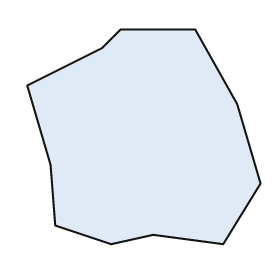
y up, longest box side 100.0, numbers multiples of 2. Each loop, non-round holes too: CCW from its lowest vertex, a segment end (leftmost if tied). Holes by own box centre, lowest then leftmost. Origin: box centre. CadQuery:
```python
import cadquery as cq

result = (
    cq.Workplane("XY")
    .moveTo(-14.0, -46.0)
    .lineTo(4.0, -42.0)
    .lineTo(34.0, -46.0)
    .lineTo(50.0, -20.0)
    .lineTo(40.0, 14.0)
    .lineTo(22.0, 46.0)
    .lineTo(-10.0, 46.0)
    .lineTo(-18.0, 38.0)
    .lineTo(-50.0, 22.0)
    .lineTo(-40.0, -12.0)
    .lineTo(-38.0, -38.0)
    .close()
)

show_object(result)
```